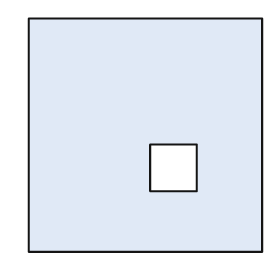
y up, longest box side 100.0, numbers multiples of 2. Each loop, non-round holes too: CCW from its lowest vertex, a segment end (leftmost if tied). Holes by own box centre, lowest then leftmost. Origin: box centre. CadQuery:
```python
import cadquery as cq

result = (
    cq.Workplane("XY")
    .moveTo(-50.0, -50.0)
    .lineTo(50.0, -50.0)
    .lineTo(50.0, 50.0)
    .lineTo(-50.0, 50.0)
    .close()
    .moveTo(2.0, -24.0)
    .lineTo(22.0, -24.0)
    .lineTo(22.0, -4.0)
    .lineTo(2.0, -4.0)
    .close()
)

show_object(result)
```